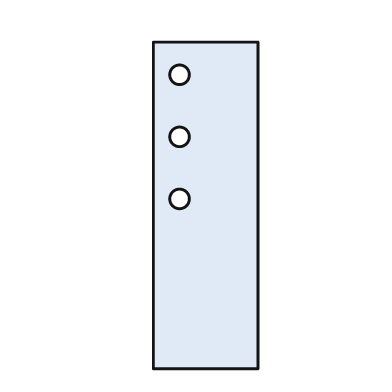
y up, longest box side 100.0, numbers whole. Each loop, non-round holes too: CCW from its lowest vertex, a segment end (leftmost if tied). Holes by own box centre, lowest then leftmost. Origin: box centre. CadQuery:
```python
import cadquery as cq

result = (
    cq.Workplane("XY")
    .moveTo(-16.0, -50.0)
    .lineTo(16.0, -50.0)
    .lineTo(16.0, 50.0)
    .lineTo(-16.0, 50.0)
    .close()
    .moveTo(-8.0, 2.0)
    .circle(3.0)
    .moveTo(-8.0, 21.0)
    .circle(3.0)
    .moveTo(-8.0, 40.0)
    .circle(3.0)
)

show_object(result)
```